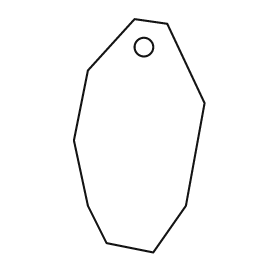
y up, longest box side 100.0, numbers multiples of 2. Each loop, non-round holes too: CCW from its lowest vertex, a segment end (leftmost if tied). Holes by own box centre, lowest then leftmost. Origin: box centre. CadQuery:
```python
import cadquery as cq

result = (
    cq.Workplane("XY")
    .moveTo(6.0, -50.0)
    .lineTo(20.0, -30.0)
    .lineTo(28.0, 14.0)
    .lineTo(12.0, 48.0)
    .lineTo(-2.0, 50.0)
    .lineTo(-22.0, 28.0)
    .lineTo(-28.0, -2.0)
    .lineTo(-22.0, -30.0)
    .lineTo(-14.0, -46.0)
    .close()
    .moveTo(2.0, 38.0)
    .circle(4.0)
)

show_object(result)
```